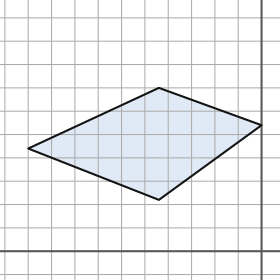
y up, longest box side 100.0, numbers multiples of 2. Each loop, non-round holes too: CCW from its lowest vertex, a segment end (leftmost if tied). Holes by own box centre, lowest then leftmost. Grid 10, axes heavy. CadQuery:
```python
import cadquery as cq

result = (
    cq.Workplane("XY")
    .moveTo(-44.0, 22.0)
    .lineTo(0.0, 54.0)
    .lineTo(-44.0, 70.0)
    .lineTo(-100.0, 44.0)
    .close()
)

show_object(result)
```